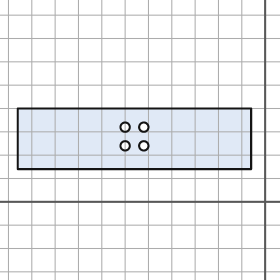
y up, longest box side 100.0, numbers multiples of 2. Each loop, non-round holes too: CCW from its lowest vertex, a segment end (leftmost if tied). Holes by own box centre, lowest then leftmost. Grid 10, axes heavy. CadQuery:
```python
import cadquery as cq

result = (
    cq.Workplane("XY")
    .moveTo(-106.0, 14.0)
    .lineTo(-6.0, 14.0)
    .lineTo(-6.0, 40.0)
    .lineTo(-106.0, 40.0)
    .close()
    .moveTo(-60.0, 24.0)
    .circle(2.0)
    .moveTo(-52.0, 24.0)
    .circle(2.0)
    .moveTo(-60.0, 32.0)
    .circle(2.0)
    .moveTo(-52.0, 32.0)
    .circle(2.0)
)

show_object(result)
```